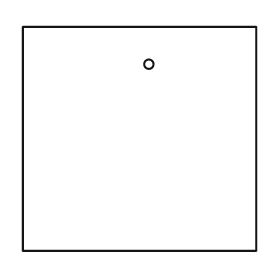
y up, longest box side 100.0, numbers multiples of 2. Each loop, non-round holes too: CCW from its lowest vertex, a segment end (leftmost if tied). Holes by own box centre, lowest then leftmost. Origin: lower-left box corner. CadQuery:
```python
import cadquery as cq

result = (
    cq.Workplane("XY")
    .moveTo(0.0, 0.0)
    .lineTo(100.0, 0.0)
    .lineTo(100.0, 96.0)
    .lineTo(0.0, 96.0)
    .close()
    .moveTo(54.0, 80.0)
    .circle(2.0)
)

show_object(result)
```